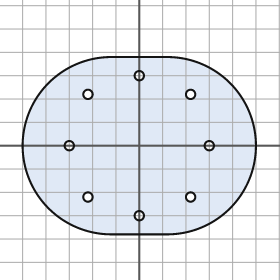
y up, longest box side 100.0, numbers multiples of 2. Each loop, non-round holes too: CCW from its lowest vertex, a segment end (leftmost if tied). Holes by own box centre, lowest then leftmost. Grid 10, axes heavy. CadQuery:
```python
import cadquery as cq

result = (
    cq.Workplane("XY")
    .moveTo(-12.0, -38.0)
    .lineTo(12.0, -38.0)
    .threePointArc((50.0, 0.0), (12.0, 38.0))
    .lineTo(-12.0, 38.0)
    .threePointArc((-50.0, 0.0), (-12.0, -38.0))
    .close()
    .moveTo(0.0, -30.0)
    .circle(2.0)
    .moveTo(-22.0, -22.0)
    .circle(2.0)
    .moveTo(22.0, -22.0)
    .circle(2.0)
    .moveTo(-30.0, 0.0)
    .circle(2.0)
    .moveTo(30.0, 0.0)
    .circle(2.0)
    .moveTo(-22.0, 22.0)
    .circle(2.0)
    .moveTo(22.0, 22.0)
    .circle(2.0)
    .moveTo(0.0, 30.0)
    .circle(2.0)
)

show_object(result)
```